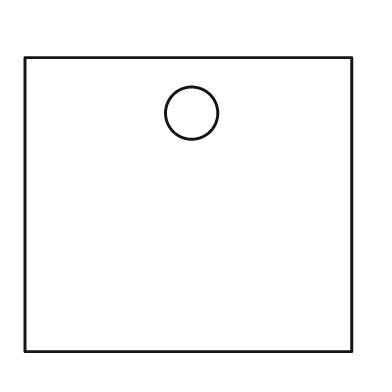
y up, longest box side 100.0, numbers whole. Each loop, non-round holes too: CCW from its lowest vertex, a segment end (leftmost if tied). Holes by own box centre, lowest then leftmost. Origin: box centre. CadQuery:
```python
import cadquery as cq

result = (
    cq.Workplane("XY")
    .moveTo(-50.0, -45.0)
    .lineTo(50.0, -45.0)
    .lineTo(50.0, 45.0)
    .lineTo(-50.0, 45.0)
    .close()
    .moveTo(1.0, 28.0)
    .circle(8.0)
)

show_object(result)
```